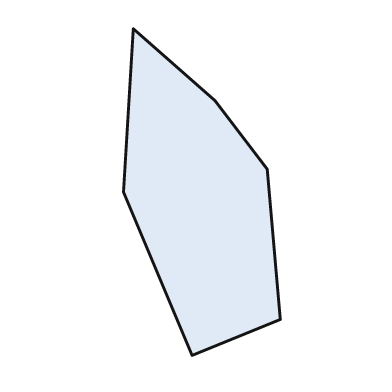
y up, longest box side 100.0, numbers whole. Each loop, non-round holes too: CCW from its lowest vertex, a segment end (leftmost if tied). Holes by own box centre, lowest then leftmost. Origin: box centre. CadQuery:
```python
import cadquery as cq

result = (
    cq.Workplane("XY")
    .moveTo(-3.0, -50.0)
    .lineTo(24.0, -39.0)
    .lineTo(20.0, 7.0)
    .lineTo(4.0, 28.0)
    .lineTo(-21.0, 50.0)
    .lineTo(-24.0, 0.0)
    .close()
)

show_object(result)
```